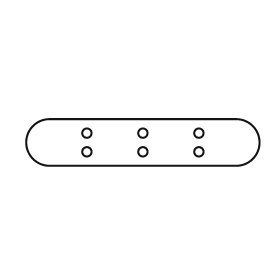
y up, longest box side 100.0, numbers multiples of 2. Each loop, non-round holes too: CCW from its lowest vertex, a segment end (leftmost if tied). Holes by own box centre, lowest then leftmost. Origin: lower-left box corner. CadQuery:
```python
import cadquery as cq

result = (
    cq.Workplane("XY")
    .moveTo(10.0, 0.0)
    .lineTo(90.0, 0.0)
    .threePointArc((100.0, 10.0), (90.0, 20.0))
    .lineTo(10.0, 20.0)
    .threePointArc((0.0, 10.0), (10.0, 0.0))
    .close()
    .moveTo(26.0, 6.0)
    .circle(2.0)
    .moveTo(50.0, 6.0)
    .circle(2.0)
    .moveTo(74.0, 6.0)
    .circle(2.0)
    .moveTo(26.0, 14.0)
    .circle(2.0)
    .moveTo(50.0, 14.0)
    .circle(2.0)
    .moveTo(74.0, 14.0)
    .circle(2.0)
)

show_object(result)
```